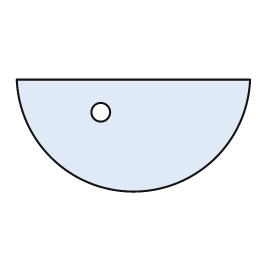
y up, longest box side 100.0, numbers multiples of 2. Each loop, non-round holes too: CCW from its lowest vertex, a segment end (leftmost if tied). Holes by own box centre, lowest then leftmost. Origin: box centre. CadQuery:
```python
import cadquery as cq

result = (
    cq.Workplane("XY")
    .moveTo(-50.0, 24.0)
    .threePointArc((0.0, -24.0), (50.0, 24.0))
    .close()
    .moveTo(-14.0, 10.0)
    .circle(4.0)
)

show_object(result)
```